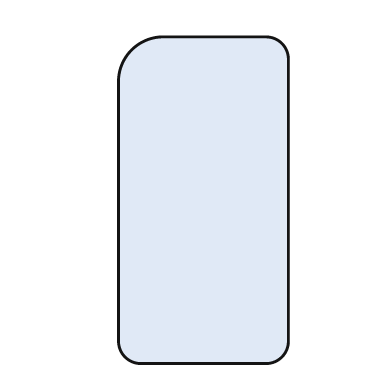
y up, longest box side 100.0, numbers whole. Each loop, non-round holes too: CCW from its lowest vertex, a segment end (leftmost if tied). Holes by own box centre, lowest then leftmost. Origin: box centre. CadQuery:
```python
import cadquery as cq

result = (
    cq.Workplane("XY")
    .moveTo(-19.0, -50.0)
    .lineTo(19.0, -50.0)
    .threePointArc((24.0, -48.0), (26.0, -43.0))
    .lineTo(26.0, 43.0)
    .threePointArc((24.0, 48.0), (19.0, 50.0))
    .lineTo(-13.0, 50.0)
    .threePointArc((-22.0, 46.0), (-26.0, 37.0))
    .lineTo(-26.0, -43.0)
    .threePointArc((-24.0, -48.0), (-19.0, -50.0))
    .close()
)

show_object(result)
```